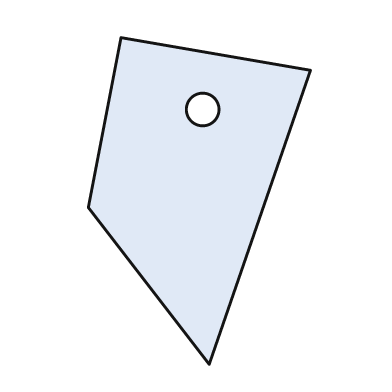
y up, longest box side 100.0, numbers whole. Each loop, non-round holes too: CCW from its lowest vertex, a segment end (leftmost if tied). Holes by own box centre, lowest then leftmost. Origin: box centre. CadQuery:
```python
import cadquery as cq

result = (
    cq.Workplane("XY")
    .moveTo(3.0, -50.0)
    .lineTo(34.0, 40.0)
    .lineTo(-24.0, 50.0)
    .lineTo(-34.0, -2.0)
    .close()
    .moveTo(1.0, 28.0)
    .circle(5.0)
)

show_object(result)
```